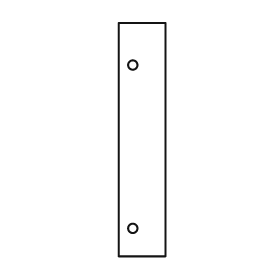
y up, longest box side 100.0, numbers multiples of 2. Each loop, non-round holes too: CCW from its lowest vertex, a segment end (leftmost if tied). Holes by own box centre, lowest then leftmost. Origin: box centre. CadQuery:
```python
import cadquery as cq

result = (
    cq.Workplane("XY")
    .moveTo(-10.0, -50.0)
    .lineTo(10.0, -50.0)
    .lineTo(10.0, 50.0)
    .lineTo(-10.0, 50.0)
    .close()
    .moveTo(-4.0, -38.0)
    .circle(2.0)
    .moveTo(-4.0, 32.0)
    .circle(2.0)
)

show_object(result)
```